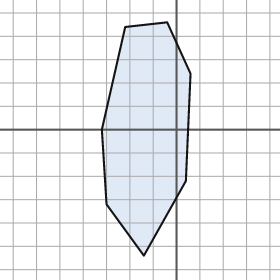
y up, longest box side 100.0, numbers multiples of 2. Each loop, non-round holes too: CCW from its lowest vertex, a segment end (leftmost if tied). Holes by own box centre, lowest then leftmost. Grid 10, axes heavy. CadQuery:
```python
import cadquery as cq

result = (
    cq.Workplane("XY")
    .moveTo(-14.0, -54.0)
    .lineTo(4.0, -22.0)
    .lineTo(6.0, 24.0)
    .lineTo(-4.0, 46.0)
    .lineTo(-22.0, 44.0)
    .lineTo(-32.0, 0.0)
    .lineTo(-30.0, -32.0)
    .close()
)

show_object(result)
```